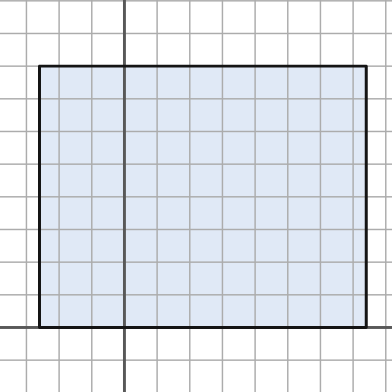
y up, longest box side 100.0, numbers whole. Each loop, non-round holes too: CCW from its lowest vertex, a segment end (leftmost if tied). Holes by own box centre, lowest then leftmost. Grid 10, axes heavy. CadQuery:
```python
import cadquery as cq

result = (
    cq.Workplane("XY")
    .moveTo(-26.0, 0.0)
    .lineTo(74.0, 0.0)
    .lineTo(74.0, 80.0)
    .lineTo(-26.0, 80.0)
    .close()
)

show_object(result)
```